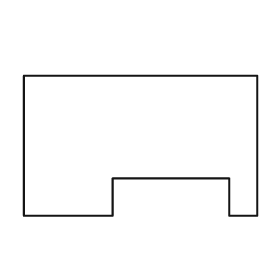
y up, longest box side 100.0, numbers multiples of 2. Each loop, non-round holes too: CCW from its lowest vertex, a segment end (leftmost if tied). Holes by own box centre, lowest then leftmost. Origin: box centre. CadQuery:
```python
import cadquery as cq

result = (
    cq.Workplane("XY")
    .moveTo(-50.0, -30.0)
    .lineTo(-12.0, -30.0)
    .lineTo(-12.0, -14.0)
    .lineTo(38.0, -14.0)
    .lineTo(38.0, -30.0)
    .lineTo(50.0, -30.0)
    .lineTo(50.0, 30.0)
    .lineTo(-50.0, 30.0)
    .close()
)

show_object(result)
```